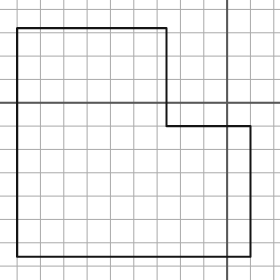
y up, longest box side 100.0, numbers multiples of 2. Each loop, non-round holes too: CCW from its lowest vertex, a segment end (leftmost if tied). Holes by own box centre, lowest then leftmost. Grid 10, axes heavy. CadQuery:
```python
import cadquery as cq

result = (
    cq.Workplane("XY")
    .moveTo(-90.0, -66.0)
    .lineTo(10.0, -66.0)
    .lineTo(10.0, -10.0)
    .lineTo(-26.0, -10.0)
    .lineTo(-26.0, 32.0)
    .lineTo(-90.0, 32.0)
    .close()
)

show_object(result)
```